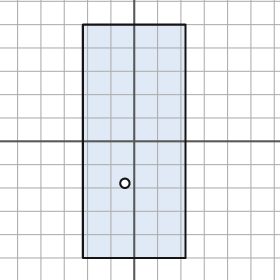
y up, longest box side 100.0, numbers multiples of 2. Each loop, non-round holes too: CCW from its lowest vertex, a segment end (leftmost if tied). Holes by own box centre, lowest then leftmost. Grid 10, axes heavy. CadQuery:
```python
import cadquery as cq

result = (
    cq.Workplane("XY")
    .moveTo(-22.0, -50.0)
    .lineTo(22.0, -50.0)
    .lineTo(22.0, 50.0)
    .lineTo(-22.0, 50.0)
    .close()
    .moveTo(-4.0, -18.0)
    .circle(2.0)
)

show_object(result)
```